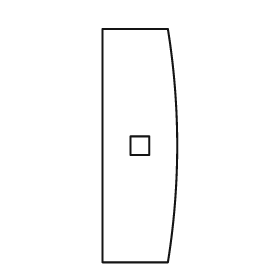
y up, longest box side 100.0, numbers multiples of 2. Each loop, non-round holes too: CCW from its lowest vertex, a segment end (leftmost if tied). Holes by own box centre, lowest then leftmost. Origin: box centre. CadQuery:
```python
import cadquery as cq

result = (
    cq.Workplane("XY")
    .moveTo(-16.0, -50.0)
    .lineTo(12.0, -50.0)
    .threePointArc((16.0, 0.0), (12.0, 50.0))
    .lineTo(-16.0, 50.0)
    .close()
    .moveTo(-4.0, -4.0)
    .lineTo(4.0, -4.0)
    .lineTo(4.0, 4.0)
    .lineTo(-4.0, 4.0)
    .close()
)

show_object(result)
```